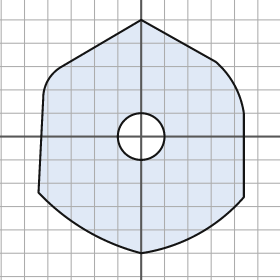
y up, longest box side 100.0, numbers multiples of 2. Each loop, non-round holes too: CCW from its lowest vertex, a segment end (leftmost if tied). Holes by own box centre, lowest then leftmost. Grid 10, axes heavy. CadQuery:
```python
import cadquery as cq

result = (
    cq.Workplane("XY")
    .moveTo(0.0, -50.0)
    .threePointArc((24.0, -42.0), (44.0, -26.0))
    .lineTo(44.0, 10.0)
    .threePointArc((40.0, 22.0), (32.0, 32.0))
    .lineTo(0.0, 50.0)
    .lineTo(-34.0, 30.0)
    .threePointArc((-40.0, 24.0), (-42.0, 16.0))
    .lineTo(-44.0, -24.0)
    .threePointArc((-24.0, -40.0), (0.0, -50.0))
    .close()
    .moveTo(0.0, 0.0)
    .circle(10.0)
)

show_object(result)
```